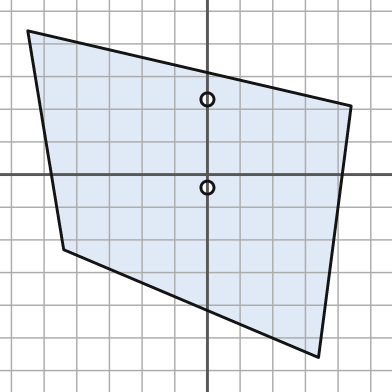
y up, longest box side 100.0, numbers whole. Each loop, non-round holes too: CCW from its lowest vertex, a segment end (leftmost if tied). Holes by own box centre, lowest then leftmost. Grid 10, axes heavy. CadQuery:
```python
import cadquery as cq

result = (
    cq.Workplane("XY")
    .moveTo(34.0, -56.0)
    .lineTo(44.0, 21.0)
    .lineTo(-55.0, 44.0)
    .lineTo(-44.0, -23.0)
    .close()
    .moveTo(0.0, -4.0)
    .circle(2.0)
    .moveTo(0.0, 23.0)
    .circle(2.0)
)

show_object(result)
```